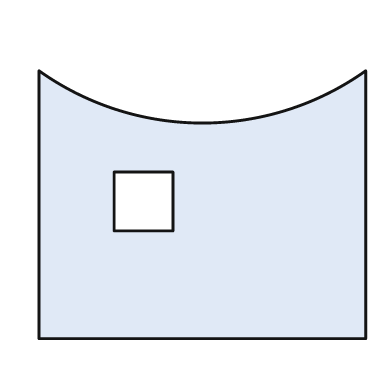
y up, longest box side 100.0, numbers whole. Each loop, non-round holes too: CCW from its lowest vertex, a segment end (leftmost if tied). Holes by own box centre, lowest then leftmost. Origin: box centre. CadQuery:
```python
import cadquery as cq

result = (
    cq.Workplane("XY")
    .moveTo(-50.0, -41.0)
    .lineTo(50.0, -41.0)
    .lineTo(50.0, 41.0)
    .threePointArc((0.0, 25.0), (-50.0, 41.0))
    .close()
    .moveTo(-27.0, -8.0)
    .lineTo(-9.0, -8.0)
    .lineTo(-9.0, 10.0)
    .lineTo(-27.0, 10.0)
    .close()
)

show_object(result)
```